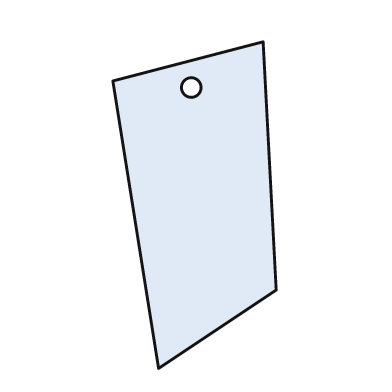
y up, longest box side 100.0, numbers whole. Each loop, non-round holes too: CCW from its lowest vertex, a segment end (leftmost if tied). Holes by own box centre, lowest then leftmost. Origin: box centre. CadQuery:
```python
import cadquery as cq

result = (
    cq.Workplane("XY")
    .moveTo(-11.0, -50.0)
    .lineTo(25.0, -26.0)
    .lineTo(21.0, 50.0)
    .lineTo(-25.0, 38.0)
    .close()
    .moveTo(-1.0, 36.0)
    .circle(3.0)
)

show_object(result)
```